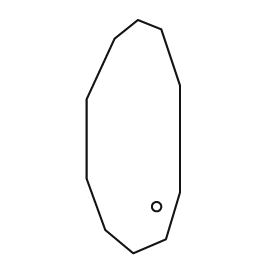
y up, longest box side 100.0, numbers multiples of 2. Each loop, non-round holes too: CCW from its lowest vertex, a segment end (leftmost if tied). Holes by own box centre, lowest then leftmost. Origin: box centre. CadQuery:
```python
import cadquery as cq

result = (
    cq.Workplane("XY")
    .moveTo(0.0, -50.0)
    .lineTo(14.0, -44.0)
    .lineTo(20.0, -24.0)
    .lineTo(20.0, 22.0)
    .lineTo(12.0, 46.0)
    .lineTo(2.0, 50.0)
    .lineTo(-8.0, 42.0)
    .lineTo(-20.0, 16.0)
    .lineTo(-20.0, -18.0)
    .lineTo(-12.0, -40.0)
    .close()
    .moveTo(10.0, -30.0)
    .circle(2.0)
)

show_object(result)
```